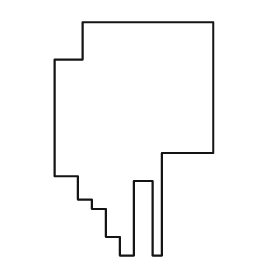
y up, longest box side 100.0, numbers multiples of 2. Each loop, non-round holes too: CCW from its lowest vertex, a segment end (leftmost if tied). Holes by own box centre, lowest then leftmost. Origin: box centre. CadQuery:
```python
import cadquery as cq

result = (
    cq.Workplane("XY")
    .moveTo(-6.0, -50.0)
    .lineTo(0.0, -50.0)
    .lineTo(0.0, -18.0)
    .lineTo(8.0, -18.0)
    .lineTo(8.0, -50.0)
    .lineTo(12.0, -50.0)
    .lineTo(12.0, -6.0)
    .lineTo(34.0, -6.0)
    .lineTo(34.0, 50.0)
    .lineTo(-22.0, 50.0)
    .lineTo(-22.0, 34.0)
    .lineTo(-34.0, 34.0)
    .lineTo(-34.0, -16.0)
    .lineTo(-24.0, -16.0)
    .lineTo(-24.0, -26.0)
    .lineTo(-18.0, -26.0)
    .lineTo(-18.0, -30.0)
    .lineTo(-12.0, -30.0)
    .lineTo(-12.0, -42.0)
    .lineTo(-6.0, -42.0)
    .close()
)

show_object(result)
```